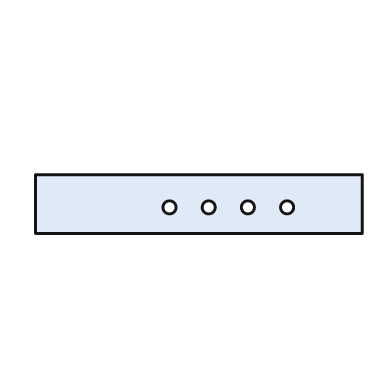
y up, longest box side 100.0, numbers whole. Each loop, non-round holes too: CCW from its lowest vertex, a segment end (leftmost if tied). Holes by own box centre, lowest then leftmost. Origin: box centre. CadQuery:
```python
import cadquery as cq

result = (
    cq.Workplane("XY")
    .moveTo(-50.0, -9.0)
    .lineTo(50.0, -9.0)
    .lineTo(50.0, 9.0)
    .lineTo(-50.0, 9.0)
    .close()
    .moveTo(-9.0, -1.0)
    .circle(2.0)
    .moveTo(3.0, -1.0)
    .circle(2.0)
    .moveTo(15.0, -1.0)
    .circle(2.0)
    .moveTo(27.0, -1.0)
    .circle(2.0)
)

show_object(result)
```